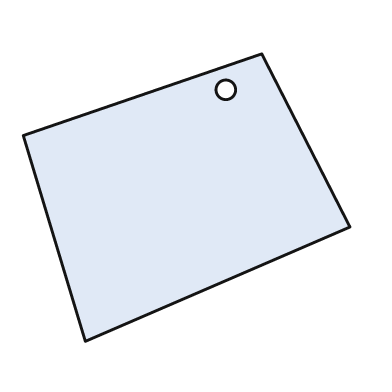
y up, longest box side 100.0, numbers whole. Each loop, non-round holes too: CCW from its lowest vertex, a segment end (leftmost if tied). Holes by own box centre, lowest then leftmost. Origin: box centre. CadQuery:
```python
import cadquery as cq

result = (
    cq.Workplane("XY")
    .moveTo(-31.0, -44.0)
    .lineTo(50.0, -9.0)
    .lineTo(23.0, 44.0)
    .lineTo(-50.0, 19.0)
    .close()
    .moveTo(12.0, 33.0)
    .circle(3.0)
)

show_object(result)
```